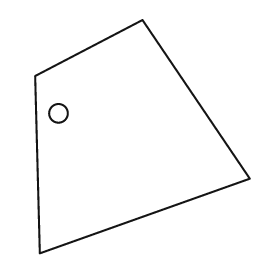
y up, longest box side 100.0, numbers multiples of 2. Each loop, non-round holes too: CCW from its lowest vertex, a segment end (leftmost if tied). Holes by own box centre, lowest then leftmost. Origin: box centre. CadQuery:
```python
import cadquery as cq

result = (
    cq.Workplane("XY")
    .moveTo(-44.0, -50.0)
    .lineTo(46.0, -18.0)
    .lineTo(0.0, 50.0)
    .lineTo(-46.0, 26.0)
    .close()
    .moveTo(-36.0, 10.0)
    .circle(4.0)
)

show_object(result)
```